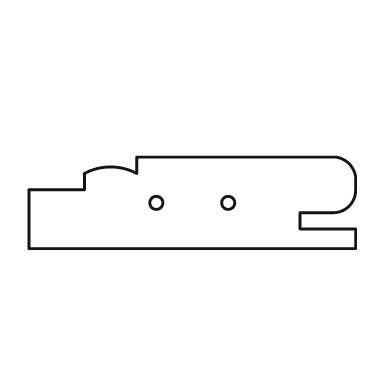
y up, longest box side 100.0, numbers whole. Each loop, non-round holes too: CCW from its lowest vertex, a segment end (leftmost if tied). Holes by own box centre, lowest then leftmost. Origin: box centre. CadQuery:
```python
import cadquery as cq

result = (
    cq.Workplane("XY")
    .moveTo(-50.0, -14.0)
    .lineTo(50.0, -14.0)
    .lineTo(50.0, -8.0)
    .lineTo(33.0, -8.0)
    .lineTo(33.0, -3.0)
    .lineTo(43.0, -3.0)
    .threePointArc((48.0, -1.0), (50.0, 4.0))
    .lineTo(50.0, 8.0)
    .threePointArc((48.0, 12.0), (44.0, 14.0))
    .lineTo(-17.0, 14.0)
    .lineTo(-17.0, 9.0)
    .threePointArc((-25.0, 11.0), (-33.0, 9.0))
    .lineTo(-33.0, 4.0)
    .lineTo(-50.0, 4.0)
    .close()
    .moveTo(-11.0, 0.0)
    .circle(2.0)
    .moveTo(11.0, 0.0)
    .circle(2.0)
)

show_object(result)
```